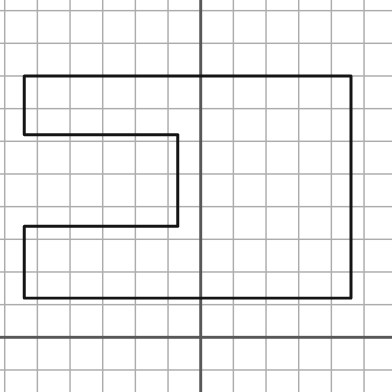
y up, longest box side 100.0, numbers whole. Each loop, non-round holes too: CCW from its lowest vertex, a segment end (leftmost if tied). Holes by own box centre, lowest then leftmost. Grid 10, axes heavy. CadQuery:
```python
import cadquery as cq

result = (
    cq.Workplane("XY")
    .moveTo(-54.0, 12.0)
    .lineTo(46.0, 12.0)
    .lineTo(46.0, 80.0)
    .lineTo(-54.0, 80.0)
    .lineTo(-54.0, 62.0)
    .lineTo(-7.0, 62.0)
    .lineTo(-7.0, 34.0)
    .lineTo(-54.0, 34.0)
    .close()
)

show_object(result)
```